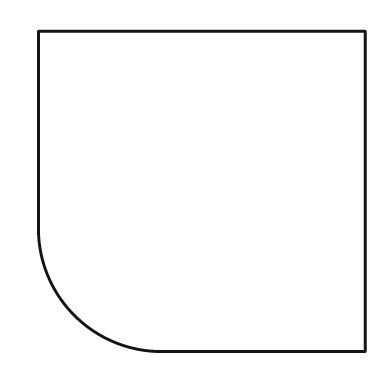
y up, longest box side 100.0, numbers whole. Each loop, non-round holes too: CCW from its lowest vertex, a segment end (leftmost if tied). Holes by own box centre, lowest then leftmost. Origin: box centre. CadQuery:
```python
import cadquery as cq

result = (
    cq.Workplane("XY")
    .moveTo(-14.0, -49.0)
    .lineTo(50.0, -49.0)
    .lineTo(50.0, 49.0)
    .lineTo(-50.0, 49.0)
    .lineTo(-50.0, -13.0)
    .threePointArc((-39.0, -38.0), (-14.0, -49.0))
    .close()
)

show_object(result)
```